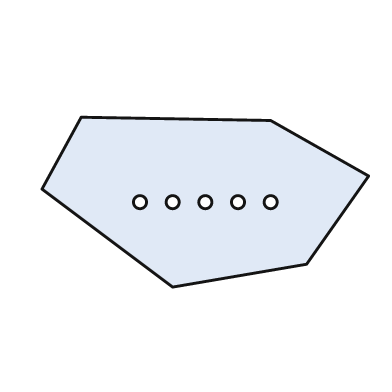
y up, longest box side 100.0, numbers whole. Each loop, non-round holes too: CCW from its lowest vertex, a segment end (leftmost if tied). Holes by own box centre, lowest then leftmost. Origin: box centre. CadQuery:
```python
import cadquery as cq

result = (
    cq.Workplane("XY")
    .moveTo(-10.0, -26.0)
    .lineTo(31.0, -19.0)
    .lineTo(50.0, 8.0)
    .lineTo(20.0, 25.0)
    .lineTo(-38.0, 26.0)
    .lineTo(-50.0, 4.0)
    .close()
    .moveTo(-20.0, 0.0)
    .circle(2.0)
    .moveTo(-10.0, 0.0)
    .circle(2.0)
    .moveTo(0.0, 0.0)
    .circle(2.0)
    .moveTo(10.0, 0.0)
    .circle(2.0)
    .moveTo(20.0, 0.0)
    .circle(2.0)
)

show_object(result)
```